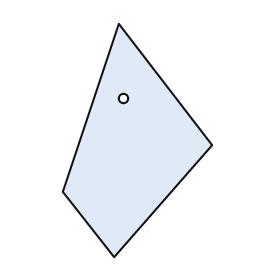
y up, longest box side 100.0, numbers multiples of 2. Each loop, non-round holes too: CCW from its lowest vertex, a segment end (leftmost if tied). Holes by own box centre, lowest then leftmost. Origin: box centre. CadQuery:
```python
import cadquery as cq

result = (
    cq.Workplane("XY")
    .moveTo(-10.0, -50.0)
    .lineTo(32.0, -2.0)
    .lineTo(-8.0, 50.0)
    .lineTo(-32.0, -22.0)
    .close()
    .moveTo(-6.0, 18.0)
    .circle(2.0)
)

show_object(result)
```